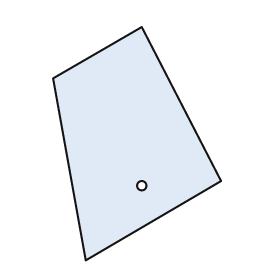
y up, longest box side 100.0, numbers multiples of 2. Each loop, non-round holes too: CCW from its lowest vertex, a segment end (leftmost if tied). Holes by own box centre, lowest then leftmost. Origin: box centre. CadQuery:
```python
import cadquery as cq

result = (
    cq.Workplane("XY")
    .moveTo(-22.0, -50.0)
    .lineTo(36.0, -16.0)
    .lineTo(2.0, 50.0)
    .lineTo(-36.0, 28.0)
    .close()
    .moveTo(2.0, -18.0)
    .circle(2.0)
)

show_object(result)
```